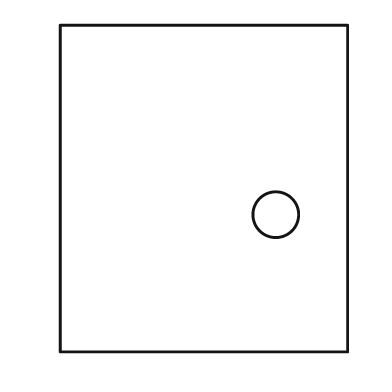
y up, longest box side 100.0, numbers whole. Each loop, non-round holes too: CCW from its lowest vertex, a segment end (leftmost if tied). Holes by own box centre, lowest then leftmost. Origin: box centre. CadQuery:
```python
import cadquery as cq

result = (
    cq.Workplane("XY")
    .moveTo(-44.0, -50.0)
    .lineTo(44.0, -50.0)
    .lineTo(44.0, 50.0)
    .lineTo(-44.0, 50.0)
    .close()
    .moveTo(22.0, -8.0)
    .circle(7.0)
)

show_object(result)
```